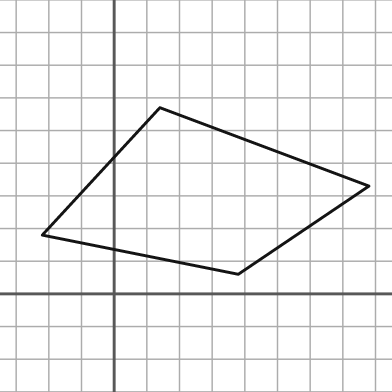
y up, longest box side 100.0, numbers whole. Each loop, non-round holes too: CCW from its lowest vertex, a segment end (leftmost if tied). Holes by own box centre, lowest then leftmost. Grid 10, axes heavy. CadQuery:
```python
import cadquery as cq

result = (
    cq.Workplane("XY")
    .moveTo(38.0, 6.0)
    .lineTo(78.0, 33.0)
    .lineTo(14.0, 57.0)
    .lineTo(-22.0, 18.0)
    .close()
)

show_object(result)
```